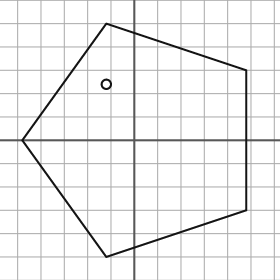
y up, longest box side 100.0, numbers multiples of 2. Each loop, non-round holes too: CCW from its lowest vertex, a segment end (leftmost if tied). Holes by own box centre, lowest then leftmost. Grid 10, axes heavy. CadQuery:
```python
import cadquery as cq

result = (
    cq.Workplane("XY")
    .moveTo(-12.0, -50.0)
    .lineTo(48.0, -30.0)
    .lineTo(48.0, 30.0)
    .lineTo(-12.0, 50.0)
    .lineTo(-48.0, 0.0)
    .close()
    .moveTo(-12.0, 24.0)
    .circle(2.0)
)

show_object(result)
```